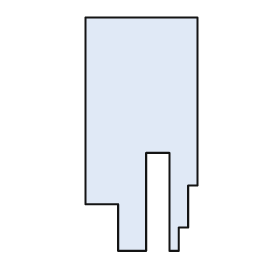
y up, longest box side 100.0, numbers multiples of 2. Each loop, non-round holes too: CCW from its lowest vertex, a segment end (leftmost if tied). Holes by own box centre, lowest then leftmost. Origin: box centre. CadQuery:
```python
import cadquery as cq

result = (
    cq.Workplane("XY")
    .moveTo(-10.0, -50.0)
    .lineTo(2.0, -50.0)
    .lineTo(2.0, -8.0)
    .lineTo(12.0, -8.0)
    .lineTo(12.0, -50.0)
    .lineTo(16.0, -50.0)
    .lineTo(16.0, -40.0)
    .lineTo(20.0, -40.0)
    .lineTo(20.0, -22.0)
    .lineTo(24.0, -22.0)
    .lineTo(24.0, 50.0)
    .lineTo(-24.0, 50.0)
    .lineTo(-24.0, -30.0)
    .lineTo(-10.0, -30.0)
    .close()
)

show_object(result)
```